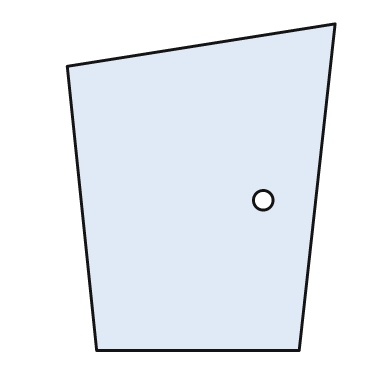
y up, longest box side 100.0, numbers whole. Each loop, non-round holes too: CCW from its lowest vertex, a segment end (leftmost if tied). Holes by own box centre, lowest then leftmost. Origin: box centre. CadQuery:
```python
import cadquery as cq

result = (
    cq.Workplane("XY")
    .moveTo(-32.0, -50.0)
    .lineTo(30.0, -50.0)
    .lineTo(41.0, 50.0)
    .lineTo(-41.0, 37.0)
    .close()
    .moveTo(19.0, -4.0)
    .circle(3.0)
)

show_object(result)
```